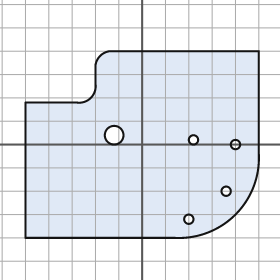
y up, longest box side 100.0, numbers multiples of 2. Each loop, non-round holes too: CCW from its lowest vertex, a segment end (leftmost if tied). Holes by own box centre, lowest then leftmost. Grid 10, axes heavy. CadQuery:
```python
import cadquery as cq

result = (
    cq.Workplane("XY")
    .moveTo(-50.0, -40.0)
    .lineTo(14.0, -40.0)
    .threePointArc((40.0, -30.0), (50.0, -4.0))
    .lineTo(50.0, 40.0)
    .lineTo(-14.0, 40.0)
    .threePointArc((-18.0, 38.0), (-20.0, 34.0))
    .lineTo(-20.0, 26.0)
    .threePointArc((-22.0, 20.0), (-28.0, 18.0))
    .lineTo(-50.0, 18.0)
    .close()
    .moveTo(20.0, -32.0)
    .circle(2.0)
    .moveTo(36.0, -20.0)
    .circle(2.0)
    .moveTo(40.0, 0.0)
    .circle(2.0)
    .moveTo(22.0, 2.0)
    .circle(2.0)
    .moveTo(-12.0, 4.0)
    .circle(4.0)
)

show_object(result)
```